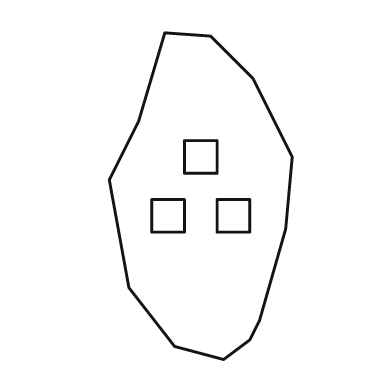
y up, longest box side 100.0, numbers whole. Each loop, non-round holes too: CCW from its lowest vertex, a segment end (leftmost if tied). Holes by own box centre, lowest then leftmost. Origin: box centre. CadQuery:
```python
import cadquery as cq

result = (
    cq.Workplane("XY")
    .moveTo(7.0, -50.0)
    .lineTo(15.0, -44.0)
    .lineTo(18.0, -38.0)
    .lineTo(26.0, -10.0)
    .lineTo(28.0, 12.0)
    .lineTo(16.0, 36.0)
    .lineTo(3.0, 49.0)
    .lineTo(-11.0, 50.0)
    .lineTo(-19.0, 23.0)
    .lineTo(-28.0, 5.0)
    .lineTo(-22.0, -28.0)
    .lineTo(-8.0, -46.0)
    .close()
    .moveTo(-15.0, -11.0)
    .lineTo(-5.0, -11.0)
    .lineTo(-5.0, -1.0)
    .lineTo(-15.0, -1.0)
    .close()
    .moveTo(5.0, -11.0)
    .lineTo(15.0, -11.0)
    .lineTo(15.0, -1.0)
    .lineTo(5.0, -1.0)
    .close()
    .moveTo(-5.0, 7.0)
    .lineTo(5.0, 7.0)
    .lineTo(5.0, 17.0)
    .lineTo(-5.0, 17.0)
    .close()
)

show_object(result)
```